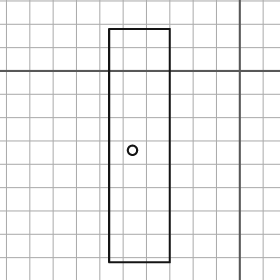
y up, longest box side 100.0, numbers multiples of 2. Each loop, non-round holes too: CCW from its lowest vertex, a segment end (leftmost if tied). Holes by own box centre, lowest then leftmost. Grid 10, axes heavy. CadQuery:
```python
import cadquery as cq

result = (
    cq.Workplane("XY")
    .moveTo(-56.0, -82.0)
    .lineTo(-30.0, -82.0)
    .lineTo(-30.0, 18.0)
    .lineTo(-56.0, 18.0)
    .close()
    .moveTo(-46.0, -34.0)
    .circle(2.0)
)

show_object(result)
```